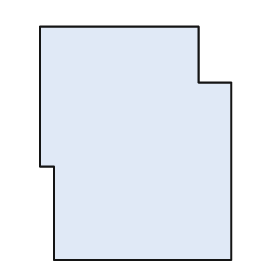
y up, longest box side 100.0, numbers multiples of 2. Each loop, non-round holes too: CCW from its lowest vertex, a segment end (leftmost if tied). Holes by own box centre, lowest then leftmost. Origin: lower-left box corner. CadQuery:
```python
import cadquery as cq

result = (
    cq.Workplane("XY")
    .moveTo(6.0, 0.0)
    .lineTo(82.0, 0.0)
    .lineTo(82.0, 76.0)
    .lineTo(68.0, 76.0)
    .lineTo(68.0, 100.0)
    .lineTo(0.0, 100.0)
    .lineTo(0.0, 40.0)
    .lineTo(6.0, 40.0)
    .close()
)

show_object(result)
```